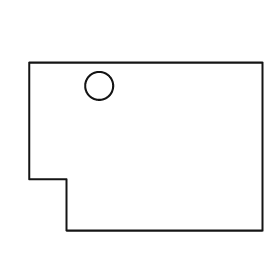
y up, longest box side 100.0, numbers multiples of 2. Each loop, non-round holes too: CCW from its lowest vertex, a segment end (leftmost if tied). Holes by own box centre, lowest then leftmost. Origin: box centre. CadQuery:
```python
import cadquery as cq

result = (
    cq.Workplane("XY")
    .moveTo(-34.0, -36.0)
    .lineTo(50.0, -36.0)
    .lineTo(50.0, 36.0)
    .lineTo(-50.0, 36.0)
    .lineTo(-50.0, -14.0)
    .lineTo(-34.0, -14.0)
    .close()
    .moveTo(-20.0, 26.0)
    .circle(6.0)
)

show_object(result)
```